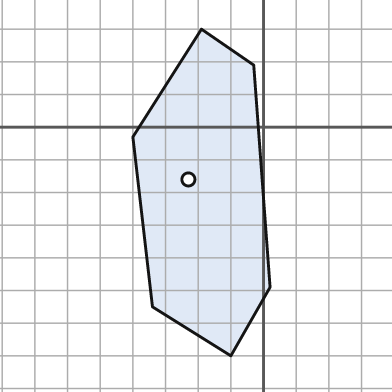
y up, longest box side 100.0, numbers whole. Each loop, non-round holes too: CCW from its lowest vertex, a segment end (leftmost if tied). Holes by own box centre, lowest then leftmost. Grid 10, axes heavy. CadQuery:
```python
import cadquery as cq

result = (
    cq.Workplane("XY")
    .moveTo(-10.0, -70.0)
    .lineTo(2.0, -49.0)
    .lineTo(-3.0, 19.0)
    .lineTo(-19.0, 30.0)
    .lineTo(-40.0, -3.0)
    .lineTo(-34.0, -55.0)
    .close()
    .moveTo(-23.0, -16.0)
    .circle(2.0)
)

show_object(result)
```